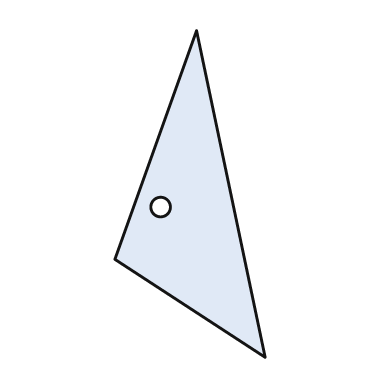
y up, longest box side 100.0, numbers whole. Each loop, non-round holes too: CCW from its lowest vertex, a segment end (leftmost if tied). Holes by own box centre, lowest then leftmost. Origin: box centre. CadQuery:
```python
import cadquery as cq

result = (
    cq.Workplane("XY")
    .moveTo(23.0, -50.0)
    .lineTo(2.0, 50.0)
    .lineTo(-23.0, -20.0)
    .close()
    .moveTo(-9.0, -4.0)
    .circle(3.0)
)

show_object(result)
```